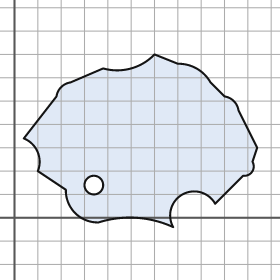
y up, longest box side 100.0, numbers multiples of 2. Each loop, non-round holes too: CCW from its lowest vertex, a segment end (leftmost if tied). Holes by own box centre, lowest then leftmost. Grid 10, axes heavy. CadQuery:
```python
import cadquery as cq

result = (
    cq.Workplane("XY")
    .moveTo(68.0, -4.0)
    .threePointArc((72.0, 10.0), (86.0, 6.0))
    .lineTo(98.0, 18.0)
    .threePointArc((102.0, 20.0), (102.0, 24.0))
    .lineTo(104.0, 30.0)
    .lineTo(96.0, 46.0)
    .threePointArc((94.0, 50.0), (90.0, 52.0))
    .lineTo(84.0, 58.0)
    .threePointArc((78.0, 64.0), (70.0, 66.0))
    .lineTo(60.0, 70.0)
    .threePointArc((50.0, 64.0), (38.0, 64.0))
    .lineTo(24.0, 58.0)
    .threePointArc((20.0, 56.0), (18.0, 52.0))
    .lineTo(4.0, 34.0)
    .threePointArc((10.0, 28.0), (10.0, 20.0))
    .lineTo(22.0, 12.0)
    .threePointArc((26.0, 2.0), (36.0, -2.0))
    .threePointArc((52.0, 0.0), (68.0, -4.0))
    .close()
    .moveTo(34.0, 14.0)
    .circle(4.0)
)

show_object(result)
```